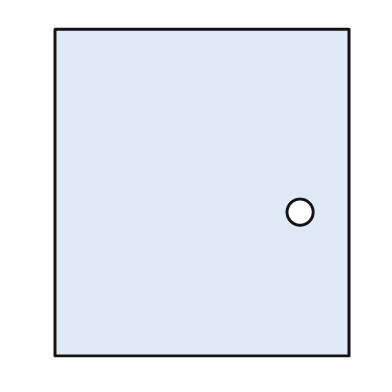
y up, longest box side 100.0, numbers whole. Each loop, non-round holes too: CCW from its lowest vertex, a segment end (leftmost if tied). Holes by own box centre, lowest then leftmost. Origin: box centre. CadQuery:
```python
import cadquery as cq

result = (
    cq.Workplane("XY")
    .moveTo(-45.0, -50.0)
    .lineTo(45.0, -50.0)
    .lineTo(45.0, 50.0)
    .lineTo(-45.0, 50.0)
    .close()
    .moveTo(30.0, -6.0)
    .circle(4.0)
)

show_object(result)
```